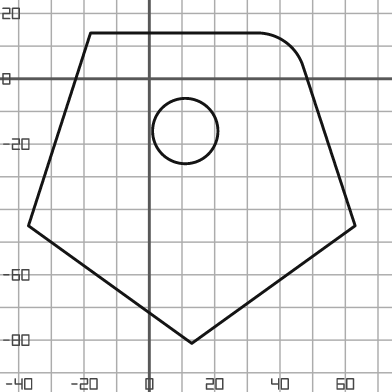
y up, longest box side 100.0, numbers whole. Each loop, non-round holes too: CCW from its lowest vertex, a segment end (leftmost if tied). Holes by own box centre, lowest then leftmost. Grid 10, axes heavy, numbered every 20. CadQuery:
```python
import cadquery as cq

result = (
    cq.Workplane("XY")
    .moveTo(13.0, -81.0)
    .lineTo(63.0, -45.0)
    .lineTo(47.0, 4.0)
    .threePointArc((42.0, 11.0), (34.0, 14.0))
    .lineTo(-18.0, 14.0)
    .lineTo(-37.0, -45.0)
    .close()
    .moveTo(11.0, -16.0)
    .circle(10.0)
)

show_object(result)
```